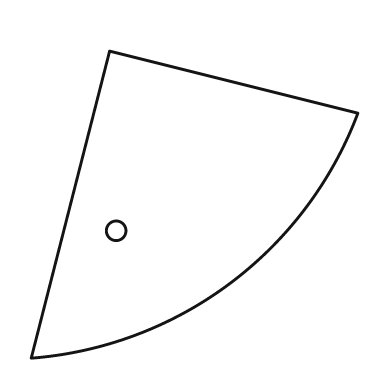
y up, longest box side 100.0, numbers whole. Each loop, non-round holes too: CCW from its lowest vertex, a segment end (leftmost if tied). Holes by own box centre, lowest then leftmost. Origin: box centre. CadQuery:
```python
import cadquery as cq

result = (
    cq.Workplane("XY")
    .moveTo(-50.0, -47.0)
    .threePointArc((11.0, -24.0), (50.0, 28.0))
    .lineTo(-26.0, 47.0)
    .close()
    .moveTo(-24.0, -8.0)
    .circle(3.0)
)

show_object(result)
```